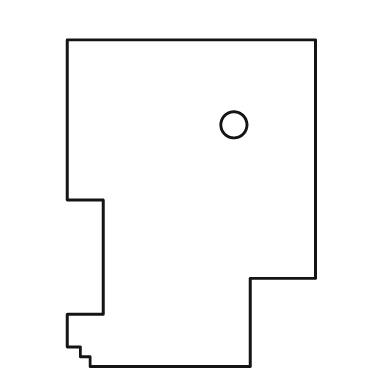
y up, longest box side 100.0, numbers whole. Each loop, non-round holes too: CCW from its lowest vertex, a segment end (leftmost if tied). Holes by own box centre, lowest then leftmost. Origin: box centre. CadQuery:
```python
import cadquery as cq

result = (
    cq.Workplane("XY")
    .moveTo(-31.0, -50.0)
    .lineTo(18.0, -50.0)
    .lineTo(18.0, -23.0)
    .lineTo(38.0, -23.0)
    .lineTo(38.0, 50.0)
    .lineTo(-38.0, 50.0)
    .lineTo(-38.0, 1.0)
    .lineTo(-27.0, 1.0)
    .lineTo(-27.0, -34.0)
    .lineTo(-38.0, -34.0)
    .lineTo(-38.0, -44.0)
    .lineTo(-34.0, -44.0)
    .lineTo(-34.0, -47.0)
    .lineTo(-31.0, -47.0)
    .close()
    .moveTo(13.0, 24.0)
    .circle(4.0)
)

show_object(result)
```